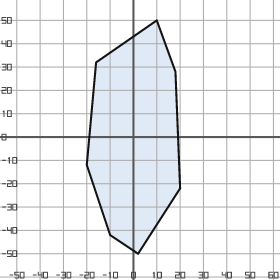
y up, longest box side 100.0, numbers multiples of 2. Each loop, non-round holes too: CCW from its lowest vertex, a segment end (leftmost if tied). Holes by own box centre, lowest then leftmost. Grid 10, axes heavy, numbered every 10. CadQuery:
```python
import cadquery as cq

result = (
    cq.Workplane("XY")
    .moveTo(2.0, -50.0)
    .lineTo(20.0, -22.0)
    .lineTo(18.0, 28.0)
    .lineTo(10.0, 50.0)
    .lineTo(-16.0, 32.0)
    .lineTo(-20.0, -12.0)
    .lineTo(-10.0, -42.0)
    .close()
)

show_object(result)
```